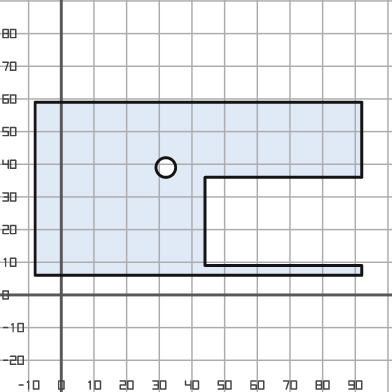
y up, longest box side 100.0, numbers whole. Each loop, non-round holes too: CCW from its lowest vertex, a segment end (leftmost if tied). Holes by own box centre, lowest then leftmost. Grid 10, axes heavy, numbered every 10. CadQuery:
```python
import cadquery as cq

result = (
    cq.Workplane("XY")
    .moveTo(-8.0, 6.0)
    .lineTo(92.0, 6.0)
    .lineTo(92.0, 9.0)
    .lineTo(44.0, 9.0)
    .lineTo(44.0, 36.0)
    .lineTo(92.0, 36.0)
    .lineTo(92.0, 59.0)
    .lineTo(-8.0, 59.0)
    .close()
    .moveTo(32.0, 39.0)
    .circle(3.0)
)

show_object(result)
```